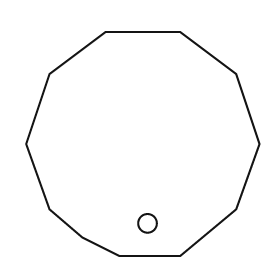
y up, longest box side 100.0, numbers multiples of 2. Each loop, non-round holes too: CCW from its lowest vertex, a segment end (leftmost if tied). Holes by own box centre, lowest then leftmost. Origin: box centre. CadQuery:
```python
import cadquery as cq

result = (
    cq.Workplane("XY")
    .moveTo(-10.0, -48.0)
    .lineTo(16.0, -48.0)
    .lineTo(40.0, -28.0)
    .lineTo(50.0, 0.0)
    .lineTo(40.0, 30.0)
    .lineTo(16.0, 48.0)
    .lineTo(-16.0, 48.0)
    .lineTo(-40.0, 30.0)
    .lineTo(-50.0, 0.0)
    .lineTo(-40.0, -28.0)
    .lineTo(-26.0, -40.0)
    .close()
    .moveTo(2.0, -34.0)
    .circle(4.0)
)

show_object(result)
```